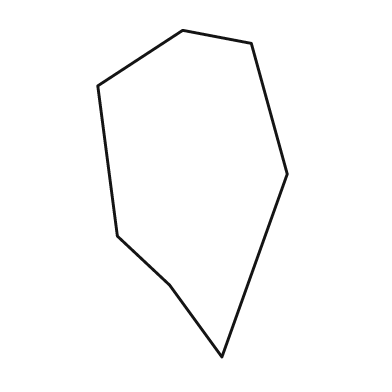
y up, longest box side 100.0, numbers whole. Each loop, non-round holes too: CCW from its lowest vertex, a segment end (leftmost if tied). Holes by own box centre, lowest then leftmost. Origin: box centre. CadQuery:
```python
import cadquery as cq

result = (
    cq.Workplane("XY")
    .moveTo(9.0, -50.0)
    .lineTo(29.0, 6.0)
    .lineTo(18.0, 46.0)
    .lineTo(-3.0, 50.0)
    .lineTo(-29.0, 33.0)
    .lineTo(-23.0, -13.0)
    .lineTo(-7.0, -28.0)
    .close()
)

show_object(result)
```